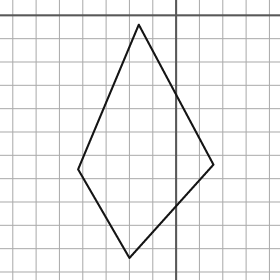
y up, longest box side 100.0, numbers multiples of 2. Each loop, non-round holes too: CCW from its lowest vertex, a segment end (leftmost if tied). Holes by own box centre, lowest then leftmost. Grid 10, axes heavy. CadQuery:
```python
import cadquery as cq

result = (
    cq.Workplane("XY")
    .moveTo(-20.0, -104.0)
    .lineTo(16.0, -64.0)
    .lineTo(-16.0, -4.0)
    .lineTo(-42.0, -66.0)
    .close()
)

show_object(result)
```